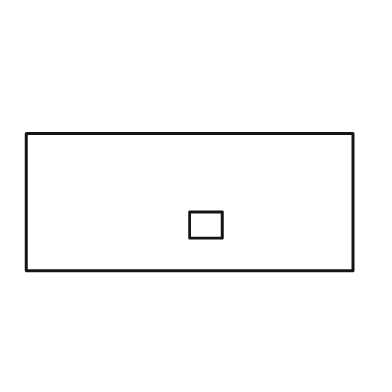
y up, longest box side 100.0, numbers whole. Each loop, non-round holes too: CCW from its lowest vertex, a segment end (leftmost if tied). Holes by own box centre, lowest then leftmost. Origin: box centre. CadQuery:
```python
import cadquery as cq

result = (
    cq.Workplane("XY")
    .moveTo(-50.0, -21.0)
    .lineTo(50.0, -21.0)
    .lineTo(50.0, 21.0)
    .lineTo(-50.0, 21.0)
    .close()
    .moveTo(0.0, -11.0)
    .lineTo(10.0, -11.0)
    .lineTo(10.0, -3.0)
    .lineTo(0.0, -3.0)
    .close()
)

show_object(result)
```